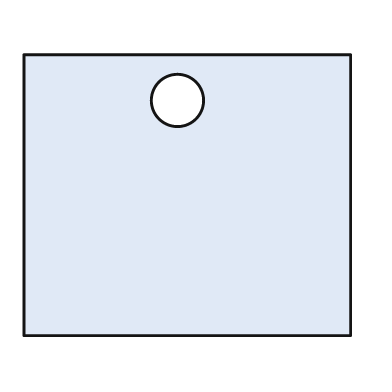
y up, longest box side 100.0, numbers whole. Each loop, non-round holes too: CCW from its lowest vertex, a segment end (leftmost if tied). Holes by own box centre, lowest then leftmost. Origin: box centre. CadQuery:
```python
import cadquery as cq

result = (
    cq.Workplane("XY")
    .moveTo(-50.0, -43.0)
    .lineTo(50.0, -43.0)
    .lineTo(50.0, 43.0)
    .lineTo(-50.0, 43.0)
    .close()
    .moveTo(-3.0, 29.0)
    .circle(8.0)
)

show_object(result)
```